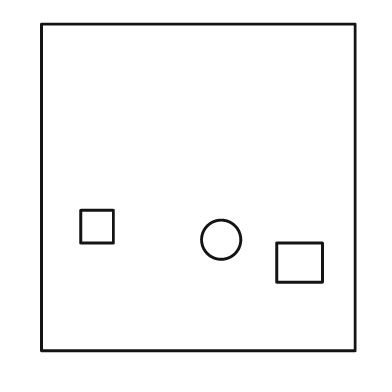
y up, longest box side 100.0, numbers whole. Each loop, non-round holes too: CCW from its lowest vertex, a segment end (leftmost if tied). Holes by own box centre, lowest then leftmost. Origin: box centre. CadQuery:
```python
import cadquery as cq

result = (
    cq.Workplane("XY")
    .moveTo(-48.0, -50.0)
    .lineTo(48.0, -50.0)
    .lineTo(48.0, 50.0)
    .lineTo(-48.0, 50.0)
    .close()
    .moveTo(24.0, -29.0)
    .lineTo(38.0, -29.0)
    .lineTo(38.0, -17.0)
    .lineTo(24.0, -17.0)
    .close()
    .moveTo(7.0, -16.0)
    .circle(6.0)
    .moveTo(-36.0, -17.0)
    .lineTo(-26.0, -17.0)
    .lineTo(-26.0, -7.0)
    .lineTo(-36.0, -7.0)
    .close()
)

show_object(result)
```